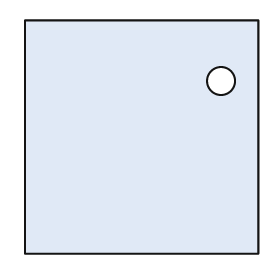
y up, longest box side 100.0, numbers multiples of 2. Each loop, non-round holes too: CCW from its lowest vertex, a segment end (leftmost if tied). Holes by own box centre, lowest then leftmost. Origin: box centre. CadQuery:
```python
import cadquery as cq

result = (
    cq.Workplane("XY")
    .moveTo(-50.0, -50.0)
    .lineTo(50.0, -50.0)
    .lineTo(50.0, 50.0)
    .lineTo(-50.0, 50.0)
    .close()
    .moveTo(34.0, 24.0)
    .circle(6.0)
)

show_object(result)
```